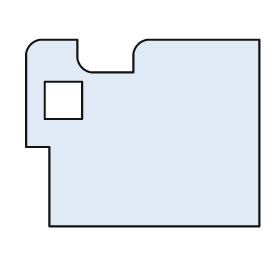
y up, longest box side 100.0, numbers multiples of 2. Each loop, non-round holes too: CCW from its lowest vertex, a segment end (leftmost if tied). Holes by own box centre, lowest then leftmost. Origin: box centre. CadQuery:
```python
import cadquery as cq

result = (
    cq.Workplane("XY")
    .moveTo(-40.0, -40.0)
    .lineTo(50.0, -40.0)
    .lineTo(50.0, 40.0)
    .lineTo(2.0, 40.0)
    .threePointArc((-2.0, 38.0), (-4.0, 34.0))
    .lineTo(-4.0, 26.0)
    .lineTo(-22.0, 26.0)
    .threePointArc((-26.0, 28.0), (-28.0, 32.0))
    .lineTo(-28.0, 40.0)
    .lineTo(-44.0, 40.0)
    .threePointArc((-48.0, 38.0), (-50.0, 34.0))
    .lineTo(-50.0, -6.0)
    .lineTo(-40.0, -6.0)
    .close()
    .moveTo(-42.0, 6.0)
    .lineTo(-26.0, 6.0)
    .lineTo(-26.0, 22.0)
    .lineTo(-42.0, 22.0)
    .close()
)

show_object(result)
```